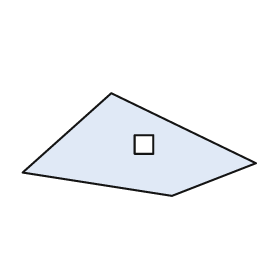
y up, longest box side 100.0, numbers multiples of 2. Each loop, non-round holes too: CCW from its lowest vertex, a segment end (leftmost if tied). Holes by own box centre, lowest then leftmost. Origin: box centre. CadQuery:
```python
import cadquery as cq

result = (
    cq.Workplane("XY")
    .moveTo(14.0, -22.0)
    .lineTo(50.0, -8.0)
    .lineTo(-12.0, 22.0)
    .lineTo(-50.0, -12.0)
    .close()
    .moveTo(-2.0, -4.0)
    .lineTo(6.0, -4.0)
    .lineTo(6.0, 4.0)
    .lineTo(-2.0, 4.0)
    .close()
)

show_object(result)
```